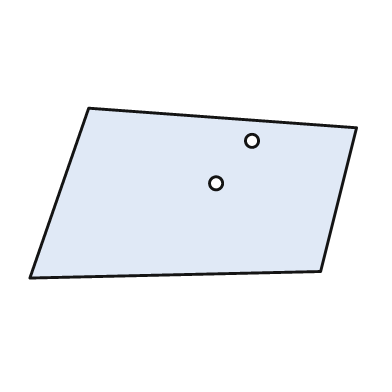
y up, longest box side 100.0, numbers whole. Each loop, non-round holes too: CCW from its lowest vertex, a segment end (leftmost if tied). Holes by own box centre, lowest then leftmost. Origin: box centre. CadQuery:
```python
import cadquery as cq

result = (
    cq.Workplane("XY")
    .moveTo(-50.0, -26.0)
    .lineTo(39.0, -24.0)
    .lineTo(50.0, 20.0)
    .lineTo(-32.0, 26.0)
    .close()
    .moveTo(7.0, 3.0)
    .circle(2.0)
    .moveTo(18.0, 16.0)
    .circle(2.0)
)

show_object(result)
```